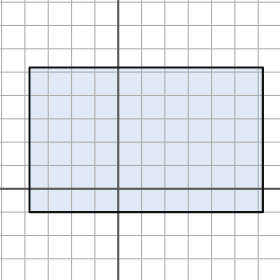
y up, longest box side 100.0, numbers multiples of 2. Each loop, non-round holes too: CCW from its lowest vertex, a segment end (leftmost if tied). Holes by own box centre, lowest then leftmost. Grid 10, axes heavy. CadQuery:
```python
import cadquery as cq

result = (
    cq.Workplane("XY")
    .moveTo(-38.0, -10.0)
    .lineTo(62.0, -10.0)
    .lineTo(62.0, 52.0)
    .lineTo(-38.0, 52.0)
    .close()
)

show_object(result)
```